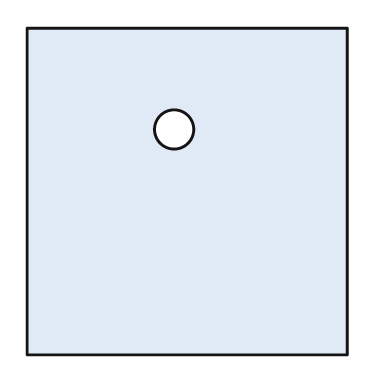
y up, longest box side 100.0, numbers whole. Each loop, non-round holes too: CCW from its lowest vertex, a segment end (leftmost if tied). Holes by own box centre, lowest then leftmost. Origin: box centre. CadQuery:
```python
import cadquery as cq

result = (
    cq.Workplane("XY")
    .moveTo(-49.0, -50.0)
    .lineTo(49.0, -50.0)
    .lineTo(49.0, 50.0)
    .lineTo(-49.0, 50.0)
    .close()
    .moveTo(-4.0, 19.0)
    .circle(6.0)
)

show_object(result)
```